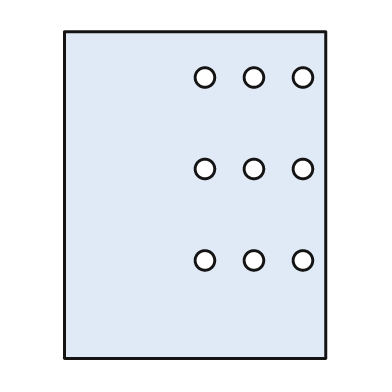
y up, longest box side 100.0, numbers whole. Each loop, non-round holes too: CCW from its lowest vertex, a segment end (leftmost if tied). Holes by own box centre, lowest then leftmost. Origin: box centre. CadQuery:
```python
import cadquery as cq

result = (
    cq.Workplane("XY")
    .moveTo(-40.0, -50.0)
    .lineTo(40.0, -50.0)
    .lineTo(40.0, 50.0)
    .lineTo(-40.0, 50.0)
    .close()
    .moveTo(3.0, -20.0)
    .circle(3.0)
    .moveTo(18.0, -20.0)
    .circle(3.0)
    .moveTo(33.0, -20.0)
    .circle(3.0)
    .moveTo(3.0, 8.0)
    .circle(3.0)
    .moveTo(18.0, 8.0)
    .circle(3.0)
    .moveTo(33.0, 8.0)
    .circle(3.0)
    .moveTo(3.0, 36.0)
    .circle(3.0)
    .moveTo(18.0, 36.0)
    .circle(3.0)
    .moveTo(33.0, 36.0)
    .circle(3.0)
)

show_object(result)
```